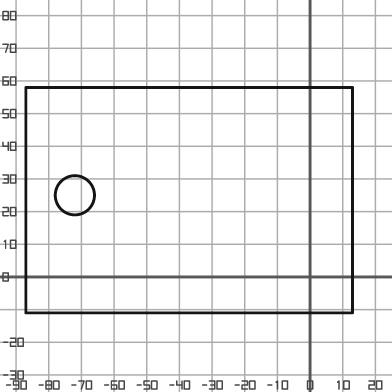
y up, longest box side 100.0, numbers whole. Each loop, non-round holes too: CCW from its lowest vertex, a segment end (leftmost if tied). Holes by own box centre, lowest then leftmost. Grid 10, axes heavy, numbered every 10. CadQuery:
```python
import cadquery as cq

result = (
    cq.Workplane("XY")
    .moveTo(-87.0, -11.0)
    .lineTo(13.0, -11.0)
    .lineTo(13.0, 58.0)
    .lineTo(-87.0, 58.0)
    .close()
    .moveTo(-72.0, 25.0)
    .circle(6.0)
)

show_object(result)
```